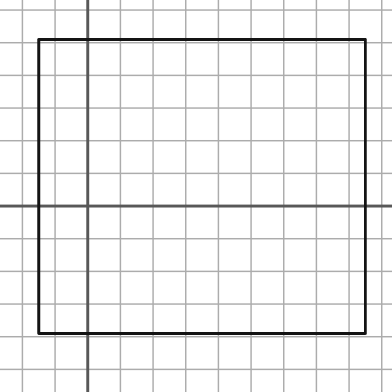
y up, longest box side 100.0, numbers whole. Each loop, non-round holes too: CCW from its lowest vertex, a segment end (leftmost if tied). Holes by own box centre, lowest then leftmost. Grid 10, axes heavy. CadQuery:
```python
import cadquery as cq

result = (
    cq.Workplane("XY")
    .moveTo(-15.0, -39.0)
    .lineTo(85.0, -39.0)
    .lineTo(85.0, 51.0)
    .lineTo(-15.0, 51.0)
    .close()
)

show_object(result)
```